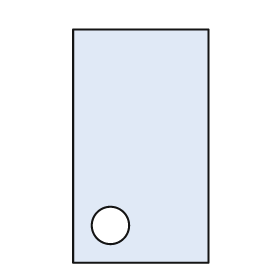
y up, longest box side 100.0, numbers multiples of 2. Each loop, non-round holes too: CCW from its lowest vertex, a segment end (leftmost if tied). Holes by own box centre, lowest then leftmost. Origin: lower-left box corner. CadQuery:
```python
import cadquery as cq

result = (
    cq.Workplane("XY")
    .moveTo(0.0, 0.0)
    .lineTo(58.0, 0.0)
    .lineTo(58.0, 100.0)
    .lineTo(0.0, 100.0)
    .close()
    .moveTo(16.0, 16.0)
    .circle(8.0)
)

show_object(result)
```